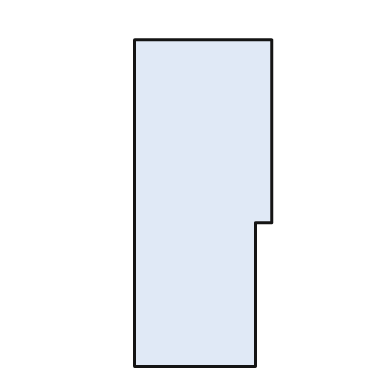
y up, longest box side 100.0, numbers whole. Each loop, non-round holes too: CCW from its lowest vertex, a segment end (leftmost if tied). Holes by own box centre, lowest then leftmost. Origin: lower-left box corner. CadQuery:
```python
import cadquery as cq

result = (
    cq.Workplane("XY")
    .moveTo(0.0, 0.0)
    .lineTo(37.0, 0.0)
    .lineTo(37.0, 44.0)
    .lineTo(42.0, 44.0)
    .lineTo(42.0, 100.0)
    .lineTo(0.0, 100.0)
    .close()
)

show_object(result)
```